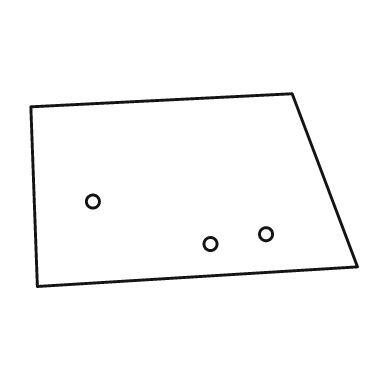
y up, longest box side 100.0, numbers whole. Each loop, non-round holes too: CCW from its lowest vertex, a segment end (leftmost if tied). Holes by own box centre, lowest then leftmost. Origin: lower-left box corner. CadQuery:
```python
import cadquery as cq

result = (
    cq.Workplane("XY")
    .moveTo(2.0, 0.0)
    .lineTo(100.0, 6.0)
    .lineTo(80.0, 59.0)
    .lineTo(0.0, 55.0)
    .close()
    .moveTo(55.0, 13.0)
    .circle(2.0)
    .moveTo(72.0, 16.0)
    .circle(2.0)
    .moveTo(19.0, 26.0)
    .circle(2.0)
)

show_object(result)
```